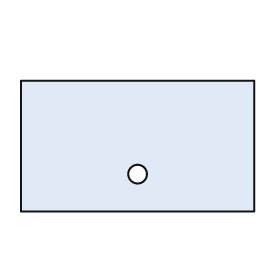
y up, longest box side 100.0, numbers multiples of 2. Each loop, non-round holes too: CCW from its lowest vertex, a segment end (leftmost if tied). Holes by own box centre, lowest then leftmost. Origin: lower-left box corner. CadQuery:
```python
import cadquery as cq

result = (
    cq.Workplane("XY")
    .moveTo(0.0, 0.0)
    .lineTo(100.0, 0.0)
    .lineTo(100.0, 56.0)
    .lineTo(0.0, 56.0)
    .close()
    .moveTo(50.0, 16.0)
    .circle(4.0)
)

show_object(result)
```